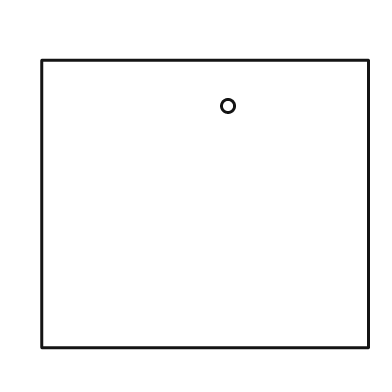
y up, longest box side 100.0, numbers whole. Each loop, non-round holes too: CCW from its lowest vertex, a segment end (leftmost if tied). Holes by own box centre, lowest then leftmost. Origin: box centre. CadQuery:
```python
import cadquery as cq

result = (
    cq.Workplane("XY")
    .moveTo(-50.0, -44.0)
    .lineTo(50.0, -44.0)
    .lineTo(50.0, 44.0)
    .lineTo(-50.0, 44.0)
    .close()
    .moveTo(7.0, 30.0)
    .circle(2.0)
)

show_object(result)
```